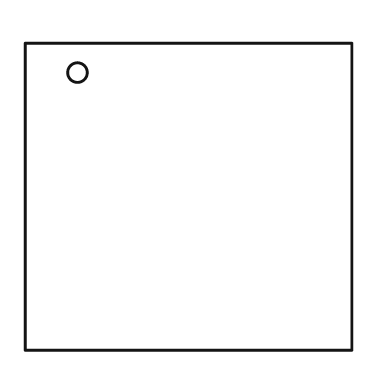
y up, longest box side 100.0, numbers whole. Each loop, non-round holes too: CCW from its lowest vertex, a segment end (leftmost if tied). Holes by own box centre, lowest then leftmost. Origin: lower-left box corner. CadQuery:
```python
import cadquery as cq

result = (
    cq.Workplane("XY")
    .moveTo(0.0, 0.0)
    .lineTo(100.0, 0.0)
    .lineTo(100.0, 94.0)
    .lineTo(0.0, 94.0)
    .close()
    .moveTo(16.0, 85.0)
    .circle(3.0)
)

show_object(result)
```